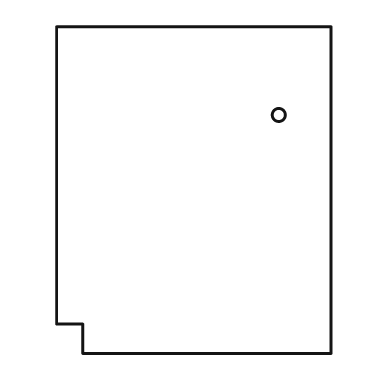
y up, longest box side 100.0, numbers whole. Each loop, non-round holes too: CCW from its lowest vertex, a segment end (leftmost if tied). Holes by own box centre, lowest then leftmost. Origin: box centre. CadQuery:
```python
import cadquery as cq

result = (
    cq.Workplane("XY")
    .moveTo(-34.0, -50.0)
    .lineTo(42.0, -50.0)
    .lineTo(42.0, 50.0)
    .lineTo(-42.0, 50.0)
    .lineTo(-42.0, -41.0)
    .lineTo(-34.0, -41.0)
    .close()
    .moveTo(26.0, 23.0)
    .circle(2.0)
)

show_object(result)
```